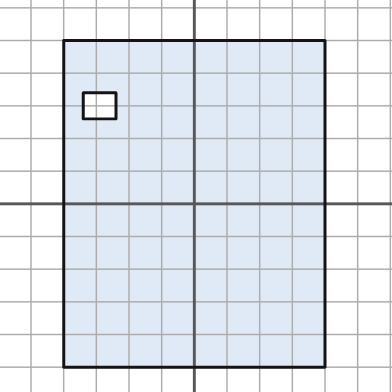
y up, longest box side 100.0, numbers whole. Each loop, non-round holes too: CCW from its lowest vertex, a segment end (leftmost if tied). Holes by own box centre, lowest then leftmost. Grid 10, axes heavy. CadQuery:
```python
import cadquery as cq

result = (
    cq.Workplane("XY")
    .moveTo(-40.0, -50.0)
    .lineTo(40.0, -50.0)
    .lineTo(40.0, 50.0)
    .lineTo(-40.0, 50.0)
    .close()
    .moveTo(-34.0, 26.0)
    .lineTo(-24.0, 26.0)
    .lineTo(-24.0, 34.0)
    .lineTo(-34.0, 34.0)
    .close()
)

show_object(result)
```